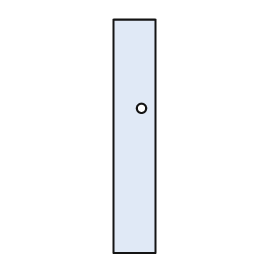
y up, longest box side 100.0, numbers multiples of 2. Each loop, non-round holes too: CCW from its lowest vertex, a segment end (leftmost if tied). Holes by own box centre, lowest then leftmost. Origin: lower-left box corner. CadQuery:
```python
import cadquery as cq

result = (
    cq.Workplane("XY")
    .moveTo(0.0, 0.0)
    .lineTo(18.0, 0.0)
    .lineTo(18.0, 100.0)
    .lineTo(0.0, 100.0)
    .close()
    .moveTo(12.0, 62.0)
    .circle(2.0)
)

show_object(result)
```